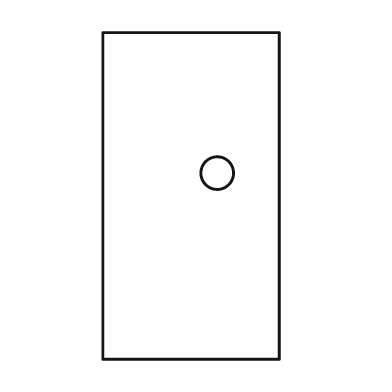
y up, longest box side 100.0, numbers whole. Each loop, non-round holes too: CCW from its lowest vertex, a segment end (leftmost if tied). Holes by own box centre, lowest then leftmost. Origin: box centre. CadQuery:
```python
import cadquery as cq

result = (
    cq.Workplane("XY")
    .moveTo(-27.0, -50.0)
    .lineTo(27.0, -50.0)
    .lineTo(27.0, 50.0)
    .lineTo(-27.0, 50.0)
    .close()
    .moveTo(8.0, 7.0)
    .circle(5.0)
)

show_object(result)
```